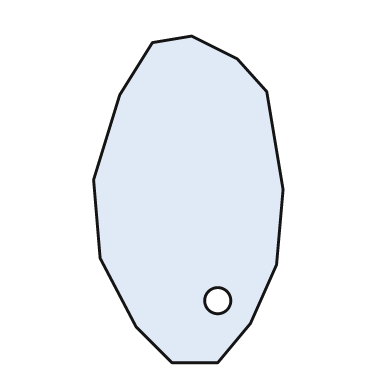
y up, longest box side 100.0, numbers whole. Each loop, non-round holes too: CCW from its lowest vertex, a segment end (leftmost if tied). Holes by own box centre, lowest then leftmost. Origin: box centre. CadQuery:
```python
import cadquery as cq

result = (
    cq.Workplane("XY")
    .moveTo(-5.0, -50.0)
    .lineTo(9.0, -50.0)
    .lineTo(19.0, -38.0)
    .lineTo(27.0, -20.0)
    .lineTo(29.0, 3.0)
    .lineTo(24.0, 33.0)
    .lineTo(15.0, 43.0)
    .lineTo(1.0, 50.0)
    .lineTo(-11.0, 48.0)
    .lineTo(-21.0, 32.0)
    .lineTo(-29.0, 6.0)
    .lineTo(-27.0, -18.0)
    .lineTo(-16.0, -39.0)
    .close()
    .moveTo(9.0, -31.0)
    .circle(4.0)
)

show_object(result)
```